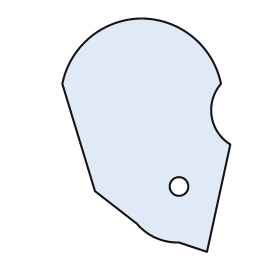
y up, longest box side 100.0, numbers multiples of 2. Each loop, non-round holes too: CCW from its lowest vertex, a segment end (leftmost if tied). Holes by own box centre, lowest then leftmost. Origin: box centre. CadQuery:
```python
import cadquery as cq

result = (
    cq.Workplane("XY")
    .moveTo(26.0, -50.0)
    .lineTo(36.0, -4.0)
    .threePointArc((28.0, 8.0), (32.0, 22.0))
    .threePointArc((20.0, 42.0), (-2.0, 50.0))
    .threePointArc((-24.0, 42.0), (-36.0, 22.0))
    .lineTo(-22.0, -24.0)
    .lineTo(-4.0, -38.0)
    .threePointArc((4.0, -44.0), (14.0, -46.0))
    .close()
    .moveTo(14.0, -22.0)
    .circle(4.0)
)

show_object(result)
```